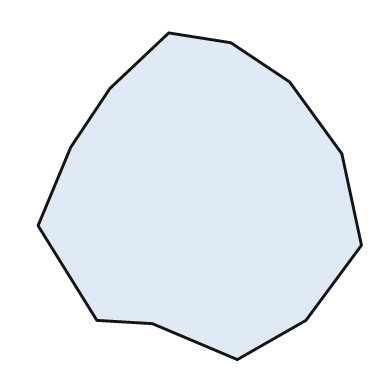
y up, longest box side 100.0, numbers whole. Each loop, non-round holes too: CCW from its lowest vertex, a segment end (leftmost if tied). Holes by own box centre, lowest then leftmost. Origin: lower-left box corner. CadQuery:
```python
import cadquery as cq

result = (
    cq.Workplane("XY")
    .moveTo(61.0, 0.0)
    .lineTo(82.0, 12.0)
    .lineTo(99.0, 35.0)
    .lineTo(93.0, 63.0)
    .lineTo(77.0, 85.0)
    .lineTo(59.0, 97.0)
    .lineTo(40.0, 100.0)
    .lineTo(22.0, 83.0)
    .lineTo(10.0, 65.0)
    .lineTo(0.0, 41.0)
    .lineTo(18.0, 12.0)
    .lineTo(35.0, 11.0)
    .close()
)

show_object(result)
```